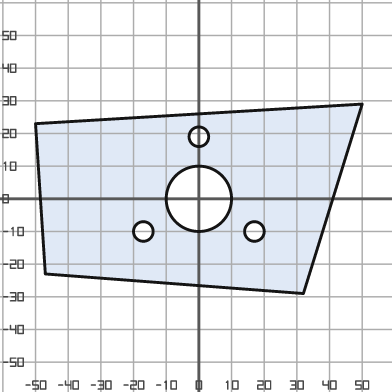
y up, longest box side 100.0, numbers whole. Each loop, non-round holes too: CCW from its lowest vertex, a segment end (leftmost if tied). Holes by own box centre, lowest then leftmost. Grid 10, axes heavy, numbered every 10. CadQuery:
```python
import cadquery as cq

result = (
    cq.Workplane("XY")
    .moveTo(32.0, -29.0)
    .lineTo(50.0, 29.0)
    .lineTo(-50.0, 23.0)
    .lineTo(-47.0, -23.0)
    .close()
    .moveTo(-17.0, -10.0)
    .circle(3.0)
    .moveTo(17.0, -10.0)
    .circle(3.0)
    .moveTo(0.0, 0.0)
    .circle(10.0)
    .moveTo(0.0, 19.0)
    .circle(3.0)
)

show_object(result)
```